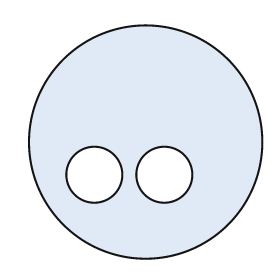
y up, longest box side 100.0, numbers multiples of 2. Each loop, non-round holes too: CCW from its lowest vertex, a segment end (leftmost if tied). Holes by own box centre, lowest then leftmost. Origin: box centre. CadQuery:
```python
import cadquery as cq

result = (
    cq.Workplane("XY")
    .moveTo(0.0, 0.0)
    .circle(50.0)
    .moveTo(-22.0, -14.0)
    .circle(12.0)
    .moveTo(8.0, -14.0)
    .circle(12.0)
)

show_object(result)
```